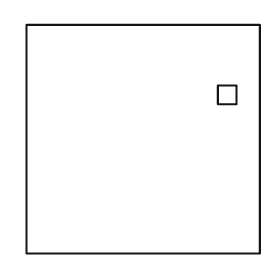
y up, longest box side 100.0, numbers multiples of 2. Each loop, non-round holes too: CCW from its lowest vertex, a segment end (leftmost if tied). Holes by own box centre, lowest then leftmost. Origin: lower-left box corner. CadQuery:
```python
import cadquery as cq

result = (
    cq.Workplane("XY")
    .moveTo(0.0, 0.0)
    .lineTo(100.0, 0.0)
    .lineTo(100.0, 98.0)
    .lineTo(0.0, 98.0)
    .close()
    .moveTo(82.0, 64.0)
    .lineTo(90.0, 64.0)
    .lineTo(90.0, 72.0)
    .lineTo(82.0, 72.0)
    .close()
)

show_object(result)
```